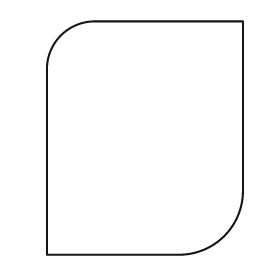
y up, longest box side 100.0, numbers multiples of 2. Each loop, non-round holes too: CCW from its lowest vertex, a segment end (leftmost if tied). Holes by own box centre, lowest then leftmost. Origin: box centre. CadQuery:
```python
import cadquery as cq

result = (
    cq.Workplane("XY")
    .moveTo(-42.0, -50.0)
    .lineTo(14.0, -50.0)
    .threePointArc((34.0, -42.0), (42.0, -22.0))
    .lineTo(42.0, 50.0)
    .lineTo(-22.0, 50.0)
    .threePointArc((-36.0, 44.0), (-42.0, 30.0))
    .close()
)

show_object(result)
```